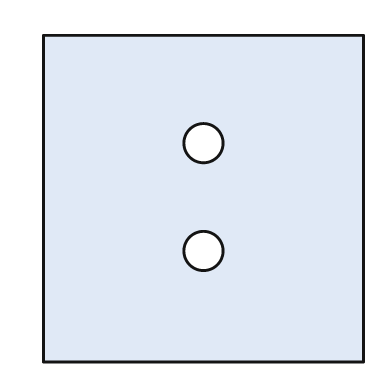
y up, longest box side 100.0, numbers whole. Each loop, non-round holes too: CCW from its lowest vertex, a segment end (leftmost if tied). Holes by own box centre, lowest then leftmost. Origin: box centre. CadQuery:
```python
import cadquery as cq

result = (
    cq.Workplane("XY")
    .moveTo(-49.0, -50.0)
    .lineTo(49.0, -50.0)
    .lineTo(49.0, 50.0)
    .lineTo(-49.0, 50.0)
    .close()
    .moveTo(0.0, -16.0)
    .circle(6.0)
    .moveTo(0.0, 17.0)
    .circle(6.0)
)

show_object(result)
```